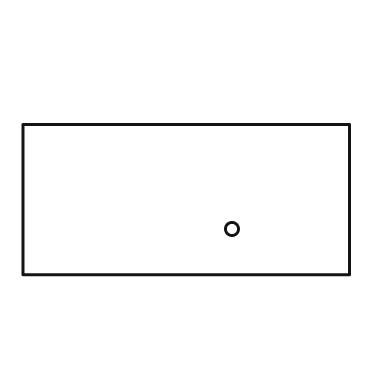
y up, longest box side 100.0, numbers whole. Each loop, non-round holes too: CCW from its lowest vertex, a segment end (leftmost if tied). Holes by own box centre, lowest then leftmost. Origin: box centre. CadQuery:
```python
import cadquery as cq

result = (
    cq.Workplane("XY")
    .moveTo(-50.0, -23.0)
    .lineTo(50.0, -23.0)
    .lineTo(50.0, 23.0)
    .lineTo(-50.0, 23.0)
    .close()
    .moveTo(14.0, -9.0)
    .circle(2.0)
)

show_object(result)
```